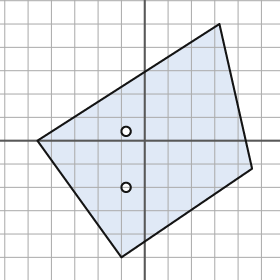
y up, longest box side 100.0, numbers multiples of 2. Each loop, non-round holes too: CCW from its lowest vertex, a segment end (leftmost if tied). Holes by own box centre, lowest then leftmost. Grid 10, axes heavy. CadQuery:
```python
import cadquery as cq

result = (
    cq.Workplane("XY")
    .moveTo(-10.0, -50.0)
    .lineTo(46.0, -12.0)
    .lineTo(32.0, 50.0)
    .lineTo(-46.0, 0.0)
    .close()
    .moveTo(-8.0, -20.0)
    .circle(2.0)
    .moveTo(-8.0, 4.0)
    .circle(2.0)
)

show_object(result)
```